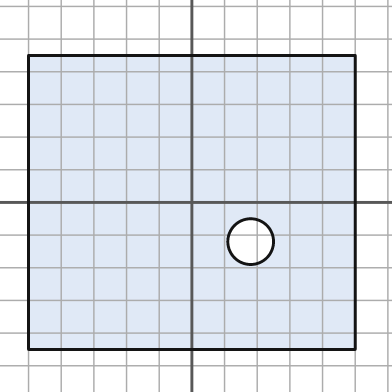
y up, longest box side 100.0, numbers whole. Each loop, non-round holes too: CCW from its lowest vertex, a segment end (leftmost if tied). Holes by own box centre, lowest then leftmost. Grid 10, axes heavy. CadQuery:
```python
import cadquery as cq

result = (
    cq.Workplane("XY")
    .moveTo(-50.0, -45.0)
    .lineTo(50.0, -45.0)
    .lineTo(50.0, 45.0)
    .lineTo(-50.0, 45.0)
    .close()
    .moveTo(18.0, -12.0)
    .circle(7.0)
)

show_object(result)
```